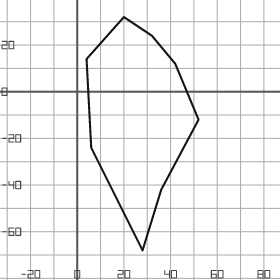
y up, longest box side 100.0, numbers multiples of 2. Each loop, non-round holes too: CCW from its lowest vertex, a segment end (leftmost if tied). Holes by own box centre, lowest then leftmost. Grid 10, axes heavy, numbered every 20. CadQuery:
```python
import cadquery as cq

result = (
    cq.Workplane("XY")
    .moveTo(28.0, -68.0)
    .lineTo(36.0, -42.0)
    .lineTo(52.0, -12.0)
    .lineTo(42.0, 12.0)
    .lineTo(32.0, 24.0)
    .lineTo(20.0, 32.0)
    .lineTo(4.0, 14.0)
    .lineTo(6.0, -24.0)
    .close()
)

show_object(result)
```